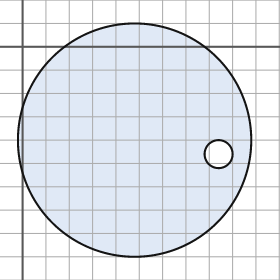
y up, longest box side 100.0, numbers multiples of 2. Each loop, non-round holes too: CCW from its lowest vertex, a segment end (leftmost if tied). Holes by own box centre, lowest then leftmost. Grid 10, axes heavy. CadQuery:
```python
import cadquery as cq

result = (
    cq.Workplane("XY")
    .moveTo(48.0, -40.0)
    .circle(50.0)
    .moveTo(84.0, -46.0)
    .circle(6.0)
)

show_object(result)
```